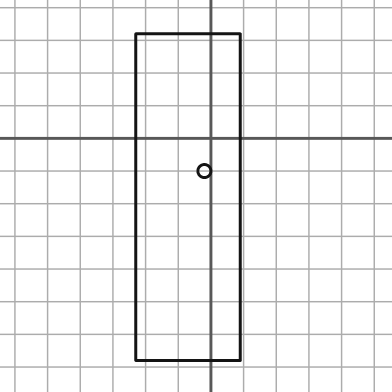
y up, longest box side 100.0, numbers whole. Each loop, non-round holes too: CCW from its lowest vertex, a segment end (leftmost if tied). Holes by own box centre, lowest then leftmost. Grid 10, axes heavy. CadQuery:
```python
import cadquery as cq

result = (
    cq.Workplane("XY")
    .moveTo(-23.0, -68.0)
    .lineTo(9.0, -68.0)
    .lineTo(9.0, 32.0)
    .lineTo(-23.0, 32.0)
    .close()
    .moveTo(-2.0, -10.0)
    .circle(2.0)
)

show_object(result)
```